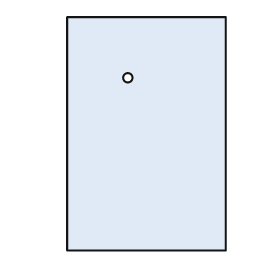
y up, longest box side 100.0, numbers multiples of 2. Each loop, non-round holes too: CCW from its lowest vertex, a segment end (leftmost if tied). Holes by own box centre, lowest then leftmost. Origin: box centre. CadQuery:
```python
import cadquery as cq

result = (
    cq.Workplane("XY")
    .moveTo(-34.0, -50.0)
    .lineTo(34.0, -50.0)
    .lineTo(34.0, 50.0)
    .lineTo(-34.0, 50.0)
    .close()
    .moveTo(-8.0, 24.0)
    .circle(2.0)
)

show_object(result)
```